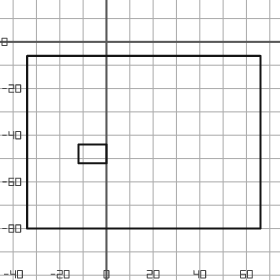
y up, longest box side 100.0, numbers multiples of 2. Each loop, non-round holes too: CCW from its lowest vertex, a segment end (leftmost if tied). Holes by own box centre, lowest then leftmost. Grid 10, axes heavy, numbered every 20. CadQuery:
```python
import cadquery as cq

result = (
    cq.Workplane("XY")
    .moveTo(-34.0, -80.0)
    .lineTo(66.0, -80.0)
    .lineTo(66.0, -6.0)
    .lineTo(-34.0, -6.0)
    .close()
    .moveTo(-12.0, -52.0)
    .lineTo(0.0, -52.0)
    .lineTo(0.0, -44.0)
    .lineTo(-12.0, -44.0)
    .close()
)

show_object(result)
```